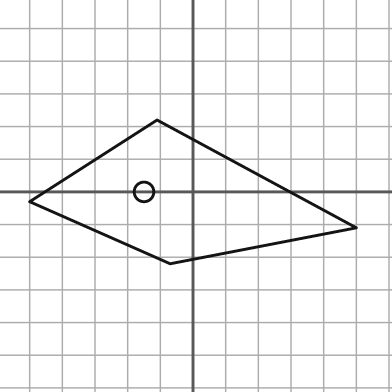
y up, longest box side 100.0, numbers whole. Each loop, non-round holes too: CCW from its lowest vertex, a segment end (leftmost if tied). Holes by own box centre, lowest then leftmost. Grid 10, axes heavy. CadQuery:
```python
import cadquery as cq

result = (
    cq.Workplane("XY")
    .moveTo(-7.0, -22.0)
    .lineTo(50.0, -11.0)
    .lineTo(-11.0, 22.0)
    .lineTo(-50.0, -3.0)
    .close()
    .moveTo(-15.0, 0.0)
    .circle(3.0)
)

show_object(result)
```